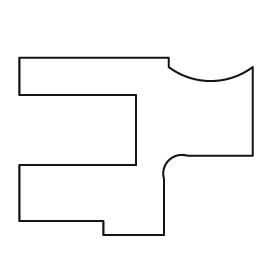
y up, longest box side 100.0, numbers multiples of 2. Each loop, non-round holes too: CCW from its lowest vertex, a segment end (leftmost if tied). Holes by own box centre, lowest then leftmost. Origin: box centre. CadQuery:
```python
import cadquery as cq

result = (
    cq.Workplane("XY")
    .moveTo(-14.0, -38.0)
    .lineTo(12.0, -38.0)
    .lineTo(12.0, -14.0)
    .threePointArc((14.0, -6.0), (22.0, -4.0))
    .lineTo(50.0, -4.0)
    .lineTo(50.0, 34.0)
    .threePointArc((32.0, 28.0), (14.0, 34.0))
    .lineTo(14.0, 38.0)
    .lineTo(-50.0, 38.0)
    .lineTo(-50.0, 22.0)
    .lineTo(0.0, 22.0)
    .lineTo(0.0, -8.0)
    .lineTo(-50.0, -8.0)
    .lineTo(-50.0, -32.0)
    .lineTo(-14.0, -32.0)
    .close()
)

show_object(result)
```